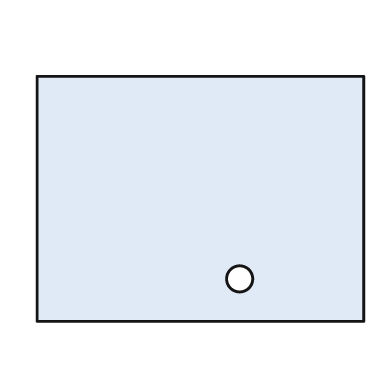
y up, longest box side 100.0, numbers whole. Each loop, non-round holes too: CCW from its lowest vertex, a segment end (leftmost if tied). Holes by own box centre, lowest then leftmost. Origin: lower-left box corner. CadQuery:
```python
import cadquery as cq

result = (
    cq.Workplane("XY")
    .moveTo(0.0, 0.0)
    .lineTo(100.0, 0.0)
    .lineTo(100.0, 75.0)
    .lineTo(0.0, 75.0)
    .close()
    .moveTo(62.0, 13.0)
    .circle(4.0)
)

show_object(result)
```